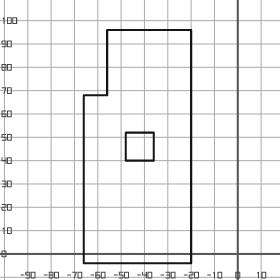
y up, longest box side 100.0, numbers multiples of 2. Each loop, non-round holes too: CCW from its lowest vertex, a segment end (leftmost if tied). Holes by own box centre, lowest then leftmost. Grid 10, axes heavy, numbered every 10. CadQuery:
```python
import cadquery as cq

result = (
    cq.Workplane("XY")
    .moveTo(-66.0, -4.0)
    .lineTo(-20.0, -4.0)
    .lineTo(-20.0, 96.0)
    .lineTo(-56.0, 96.0)
    .lineTo(-56.0, 68.0)
    .lineTo(-66.0, 68.0)
    .close()
    .moveTo(-48.0, 40.0)
    .lineTo(-36.0, 40.0)
    .lineTo(-36.0, 52.0)
    .lineTo(-48.0, 52.0)
    .close()
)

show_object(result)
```